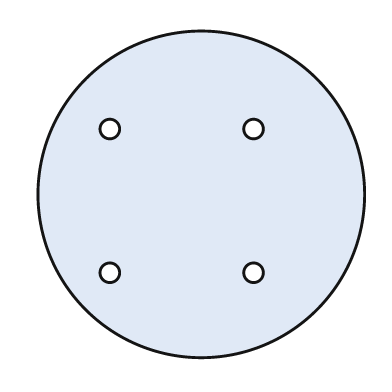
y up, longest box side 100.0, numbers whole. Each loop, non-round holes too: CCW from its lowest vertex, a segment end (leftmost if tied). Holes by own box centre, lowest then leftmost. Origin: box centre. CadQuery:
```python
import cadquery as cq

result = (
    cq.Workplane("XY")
    .moveTo(0.0, 0.0)
    .circle(50.0)
    .moveTo(-28.0, -24.0)
    .circle(3.0)
    .moveTo(16.0, -24.0)
    .circle(3.0)
    .moveTo(-28.0, 20.0)
    .circle(3.0)
    .moveTo(16.0, 20.0)
    .circle(3.0)
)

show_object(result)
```